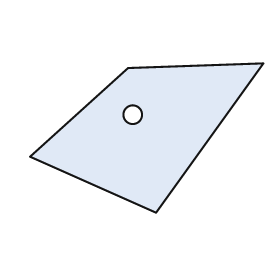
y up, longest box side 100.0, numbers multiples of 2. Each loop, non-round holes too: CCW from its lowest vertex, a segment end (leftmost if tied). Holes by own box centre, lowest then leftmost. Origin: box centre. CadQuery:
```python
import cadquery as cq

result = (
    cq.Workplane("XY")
    .moveTo(4.0, -32.0)
    .lineTo(50.0, 32.0)
    .lineTo(-8.0, 30.0)
    .lineTo(-50.0, -8.0)
    .close()
    .moveTo(-6.0, 10.0)
    .circle(4.0)
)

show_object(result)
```